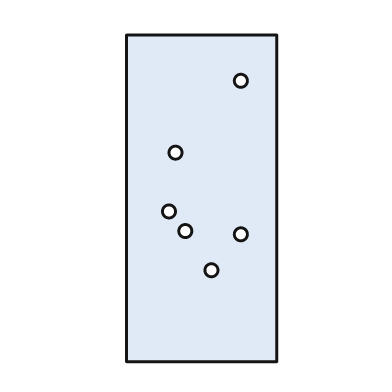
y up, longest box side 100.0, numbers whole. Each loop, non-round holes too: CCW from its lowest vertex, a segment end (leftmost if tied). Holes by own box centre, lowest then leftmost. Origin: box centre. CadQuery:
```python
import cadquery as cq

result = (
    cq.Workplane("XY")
    .moveTo(-23.0, -50.0)
    .lineTo(23.0, -50.0)
    .lineTo(23.0, 50.0)
    .lineTo(-23.0, 50.0)
    .close()
    .moveTo(3.0, -22.0)
    .circle(2.0)
    .moveTo(12.0, -11.0)
    .circle(2.0)
    .moveTo(-5.0, -10.0)
    .circle(2.0)
    .moveTo(-10.0, -4.0)
    .circle(2.0)
    .moveTo(-8.0, 14.0)
    .circle(2.0)
    .moveTo(12.0, 36.0)
    .circle(2.0)
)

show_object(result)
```